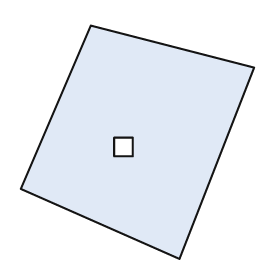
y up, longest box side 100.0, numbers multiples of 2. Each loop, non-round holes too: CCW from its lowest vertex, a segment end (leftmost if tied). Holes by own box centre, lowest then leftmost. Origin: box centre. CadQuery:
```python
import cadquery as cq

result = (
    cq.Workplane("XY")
    .moveTo(18.0, -50.0)
    .lineTo(50.0, 32.0)
    .lineTo(-20.0, 50.0)
    .lineTo(-50.0, -20.0)
    .close()
    .moveTo(-10.0, -6.0)
    .lineTo(-2.0, -6.0)
    .lineTo(-2.0, 2.0)
    .lineTo(-10.0, 2.0)
    .close()
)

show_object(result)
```